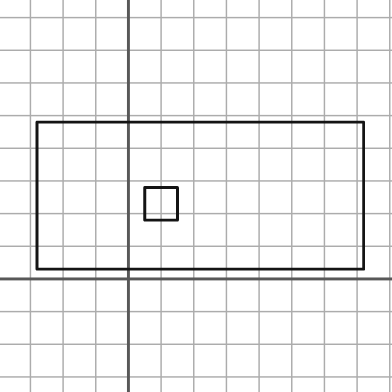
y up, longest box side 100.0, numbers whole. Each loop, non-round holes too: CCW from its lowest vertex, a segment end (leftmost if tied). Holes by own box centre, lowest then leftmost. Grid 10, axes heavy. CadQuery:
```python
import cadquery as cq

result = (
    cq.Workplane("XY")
    .moveTo(-28.0, 3.0)
    .lineTo(72.0, 3.0)
    .lineTo(72.0, 48.0)
    .lineTo(-28.0, 48.0)
    .close()
    .moveTo(5.0, 18.0)
    .lineTo(15.0, 18.0)
    .lineTo(15.0, 28.0)
    .lineTo(5.0, 28.0)
    .close()
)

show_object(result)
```